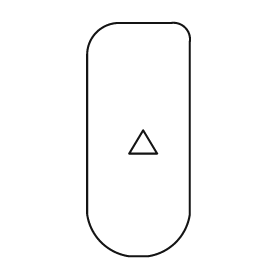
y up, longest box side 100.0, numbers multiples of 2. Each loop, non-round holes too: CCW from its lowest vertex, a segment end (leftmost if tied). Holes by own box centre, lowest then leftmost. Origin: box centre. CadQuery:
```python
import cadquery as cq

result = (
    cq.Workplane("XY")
    .moveTo(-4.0, -50.0)
    .lineTo(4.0, -50.0)
    .threePointArc((16.0, -44.0), (22.0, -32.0))
    .lineTo(22.0, 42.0)
    .threePointArc((20.0, 48.0), (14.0, 50.0))
    .lineTo(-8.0, 50.0)
    .threePointArc((-18.0, 46.0), (-22.0, 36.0))
    .lineTo(-22.0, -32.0)
    .threePointArc((-16.0, -44.0), (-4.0, -50.0))
    .close()
    .moveTo(-4.0, -6.0)
    .lineTo(8.0, -6.0)
    .lineTo(2.0, 4.0)
    .close()
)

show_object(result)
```